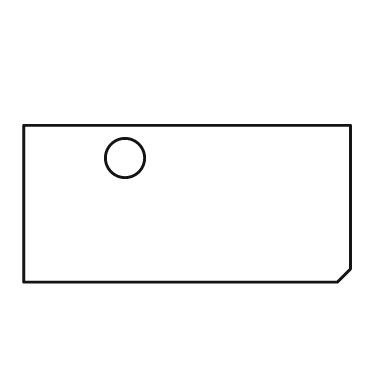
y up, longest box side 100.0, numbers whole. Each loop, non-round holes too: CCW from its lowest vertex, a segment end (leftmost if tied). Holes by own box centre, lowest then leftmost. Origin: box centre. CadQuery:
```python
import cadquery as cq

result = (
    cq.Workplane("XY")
    .moveTo(-50.0, -24.0)
    .lineTo(46.0, -24.0)
    .lineTo(50.0, -20.0)
    .lineTo(50.0, 24.0)
    .lineTo(-50.0, 24.0)
    .close()
    .moveTo(-19.0, 14.0)
    .circle(6.0)
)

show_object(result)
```